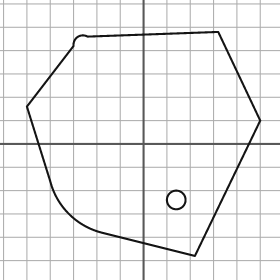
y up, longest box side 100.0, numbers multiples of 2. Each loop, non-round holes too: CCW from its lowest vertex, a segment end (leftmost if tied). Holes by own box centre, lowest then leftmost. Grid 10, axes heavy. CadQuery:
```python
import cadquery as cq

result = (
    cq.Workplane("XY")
    .moveTo(22.0, -48.0)
    .lineTo(50.0, 10.0)
    .lineTo(32.0, 48.0)
    .lineTo(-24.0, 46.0)
    .threePointArc((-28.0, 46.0), (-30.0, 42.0))
    .lineTo(-50.0, 16.0)
    .lineTo(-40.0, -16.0)
    .threePointArc((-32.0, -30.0), (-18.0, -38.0))
    .close()
    .moveTo(14.0, -24.0)
    .circle(4.0)
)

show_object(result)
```